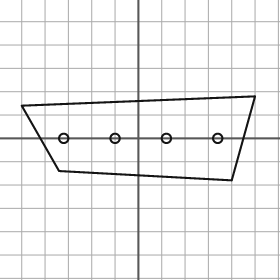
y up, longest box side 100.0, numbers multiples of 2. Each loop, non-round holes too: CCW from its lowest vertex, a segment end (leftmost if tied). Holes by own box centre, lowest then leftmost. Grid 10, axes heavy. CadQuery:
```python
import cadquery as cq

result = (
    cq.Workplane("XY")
    .moveTo(40.0, -18.0)
    .lineTo(50.0, 18.0)
    .lineTo(-50.0, 14.0)
    .lineTo(-34.0, -14.0)
    .close()
    .moveTo(-32.0, 0.0)
    .circle(2.0)
    .moveTo(-10.0, 0.0)
    .circle(2.0)
    .moveTo(12.0, 0.0)
    .circle(2.0)
    .moveTo(34.0, 0.0)
    .circle(2.0)
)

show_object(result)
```